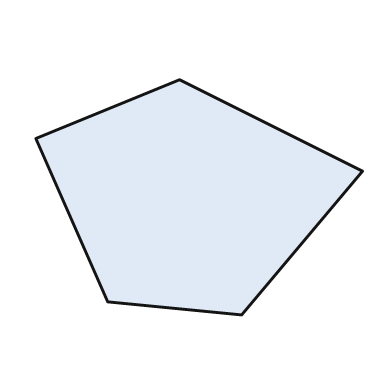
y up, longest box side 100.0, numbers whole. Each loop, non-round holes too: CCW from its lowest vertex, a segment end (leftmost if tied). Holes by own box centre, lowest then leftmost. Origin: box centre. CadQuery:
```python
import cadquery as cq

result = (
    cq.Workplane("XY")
    .moveTo(13.0, -36.0)
    .lineTo(50.0, 8.0)
    .lineTo(-6.0, 36.0)
    .lineTo(-50.0, 18.0)
    .lineTo(-28.0, -32.0)
    .close()
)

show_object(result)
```